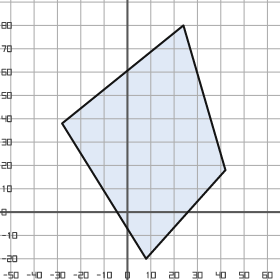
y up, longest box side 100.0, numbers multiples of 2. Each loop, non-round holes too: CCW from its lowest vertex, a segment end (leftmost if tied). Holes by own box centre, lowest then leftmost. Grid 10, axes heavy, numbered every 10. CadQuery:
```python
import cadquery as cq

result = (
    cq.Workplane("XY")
    .moveTo(8.0, -20.0)
    .lineTo(42.0, 18.0)
    .lineTo(24.0, 80.0)
    .lineTo(-28.0, 38.0)
    .close()
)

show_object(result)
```